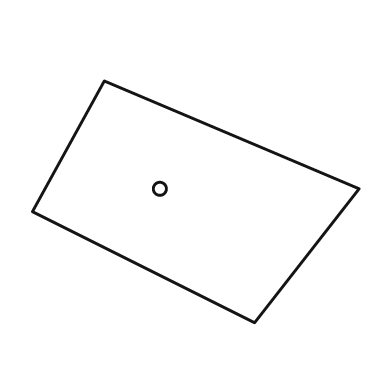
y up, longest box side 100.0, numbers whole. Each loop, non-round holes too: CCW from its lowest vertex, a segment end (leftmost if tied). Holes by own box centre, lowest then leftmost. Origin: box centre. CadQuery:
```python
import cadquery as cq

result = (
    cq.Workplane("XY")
    .moveTo(18.0, -37.0)
    .lineTo(50.0, 4.0)
    .lineTo(-28.0, 37.0)
    .lineTo(-50.0, -3.0)
    .close()
    .moveTo(-11.0, 4.0)
    .circle(2.0)
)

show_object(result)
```